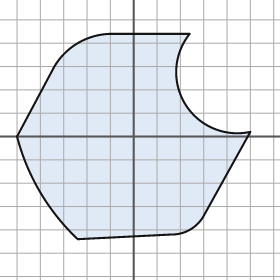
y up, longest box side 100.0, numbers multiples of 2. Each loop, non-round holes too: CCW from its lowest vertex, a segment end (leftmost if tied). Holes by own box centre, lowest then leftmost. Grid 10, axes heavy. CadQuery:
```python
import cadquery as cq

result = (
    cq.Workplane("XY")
    .moveTo(-24.0, -44.0)
    .lineTo(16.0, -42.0)
    .threePointArc((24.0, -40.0), (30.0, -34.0))
    .lineTo(50.0, 2.0)
    .threePointArc((22.0, 14.0), (24.0, 44.0))
    .lineTo(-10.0, 44.0)
    .threePointArc((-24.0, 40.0), (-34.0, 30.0))
    .lineTo(-50.0, 0.0)
    .threePointArc((-40.0, -24.0), (-24.0, -44.0))
    .close()
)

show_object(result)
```